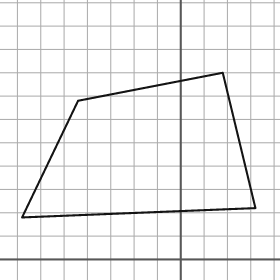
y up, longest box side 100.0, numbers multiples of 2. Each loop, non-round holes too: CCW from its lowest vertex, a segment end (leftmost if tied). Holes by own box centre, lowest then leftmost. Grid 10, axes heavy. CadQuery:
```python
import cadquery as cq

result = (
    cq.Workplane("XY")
    .moveTo(-68.0, 18.0)
    .lineTo(32.0, 22.0)
    .lineTo(18.0, 80.0)
    .lineTo(-44.0, 68.0)
    .close()
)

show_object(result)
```